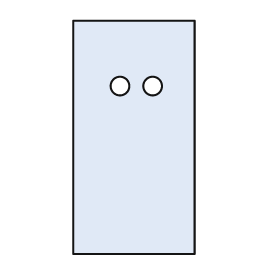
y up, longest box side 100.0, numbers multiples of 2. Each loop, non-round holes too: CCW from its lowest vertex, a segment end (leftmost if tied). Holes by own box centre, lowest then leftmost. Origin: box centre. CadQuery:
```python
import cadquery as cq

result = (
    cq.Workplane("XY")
    .moveTo(-26.0, -50.0)
    .lineTo(26.0, -50.0)
    .lineTo(26.0, 50.0)
    .lineTo(-26.0, 50.0)
    .close()
    .moveTo(-6.0, 22.0)
    .circle(4.0)
    .moveTo(8.0, 22.0)
    .circle(4.0)
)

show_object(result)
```